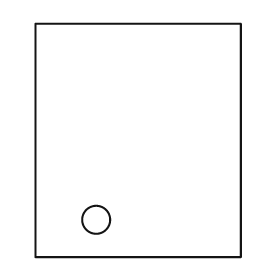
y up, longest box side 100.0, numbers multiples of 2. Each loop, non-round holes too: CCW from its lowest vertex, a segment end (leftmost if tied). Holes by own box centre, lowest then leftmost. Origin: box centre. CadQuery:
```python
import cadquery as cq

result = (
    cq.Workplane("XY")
    .moveTo(-44.0, -50.0)
    .lineTo(44.0, -50.0)
    .lineTo(44.0, 50.0)
    .lineTo(-44.0, 50.0)
    .close()
    .moveTo(-18.0, -34.0)
    .circle(6.0)
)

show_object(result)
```